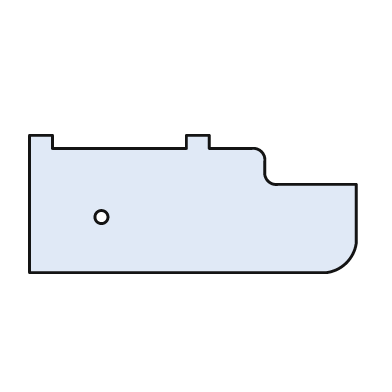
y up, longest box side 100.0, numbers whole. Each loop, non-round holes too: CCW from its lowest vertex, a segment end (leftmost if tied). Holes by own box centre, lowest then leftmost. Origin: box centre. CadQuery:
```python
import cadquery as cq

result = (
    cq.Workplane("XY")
    .moveTo(-50.0, -21.0)
    .lineTo(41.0, -21.0)
    .threePointArc((47.0, -18.0), (50.0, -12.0))
    .lineTo(50.0, 6.0)
    .lineTo(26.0, 6.0)
    .threePointArc((23.0, 7.0), (22.0, 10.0))
    .lineTo(22.0, 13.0)
    .threePointArc((21.0, 16.0), (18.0, 17.0))
    .lineTo(5.0, 17.0)
    .lineTo(5.0, 21.0)
    .lineTo(-2.0, 21.0)
    .lineTo(-2.0, 17.0)
    .lineTo(-43.0, 17.0)
    .lineTo(-43.0, 21.0)
    .lineTo(-50.0, 21.0)
    .close()
    .moveTo(-28.0, -4.0)
    .circle(2.0)
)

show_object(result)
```